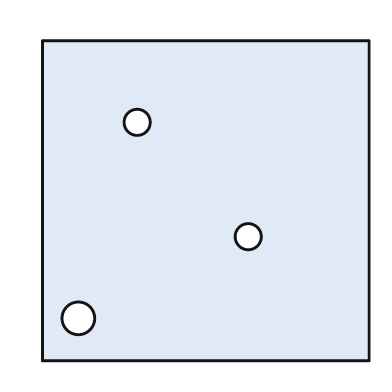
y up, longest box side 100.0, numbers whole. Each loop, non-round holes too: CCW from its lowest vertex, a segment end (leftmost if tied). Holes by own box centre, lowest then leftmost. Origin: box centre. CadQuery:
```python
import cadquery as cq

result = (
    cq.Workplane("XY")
    .moveTo(-50.0, -49.0)
    .lineTo(50.0, -49.0)
    .lineTo(50.0, 49.0)
    .lineTo(-50.0, 49.0)
    .close()
    .moveTo(-39.0, -36.0)
    .circle(5.0)
    .moveTo(13.0, -11.0)
    .circle(4.0)
    .moveTo(-21.0, 24.0)
    .circle(4.0)
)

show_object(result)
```